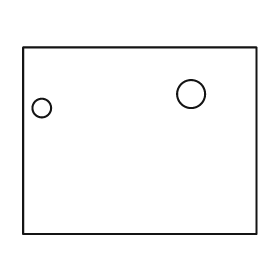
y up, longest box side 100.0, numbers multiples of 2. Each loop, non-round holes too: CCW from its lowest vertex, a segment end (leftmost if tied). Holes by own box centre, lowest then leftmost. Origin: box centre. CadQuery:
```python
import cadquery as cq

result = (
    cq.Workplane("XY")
    .moveTo(-50.0, -40.0)
    .lineTo(50.0, -40.0)
    .lineTo(50.0, 40.0)
    .lineTo(-50.0, 40.0)
    .close()
    .moveTo(-42.0, 14.0)
    .circle(4.0)
    .moveTo(22.0, 20.0)
    .circle(6.0)
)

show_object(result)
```